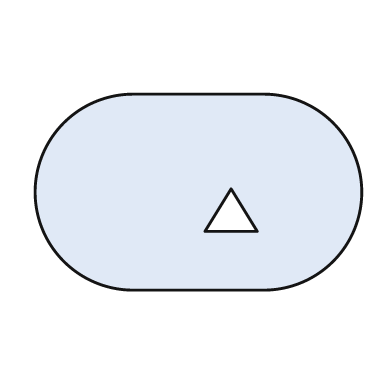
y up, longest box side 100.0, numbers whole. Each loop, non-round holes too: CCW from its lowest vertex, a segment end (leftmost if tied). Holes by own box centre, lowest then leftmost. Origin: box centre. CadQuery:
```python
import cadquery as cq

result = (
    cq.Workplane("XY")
    .moveTo(-20.0, -30.0)
    .lineTo(20.0, -30.0)
    .threePointArc((50.0, 0.0), (20.0, 30.0))
    .lineTo(-20.0, 30.0)
    .threePointArc((-50.0, 0.0), (-20.0, -30.0))
    .close()
    .moveTo(2.0, -12.0)
    .lineTo(18.0, -12.0)
    .lineTo(10.0, 1.0)
    .close()
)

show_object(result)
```